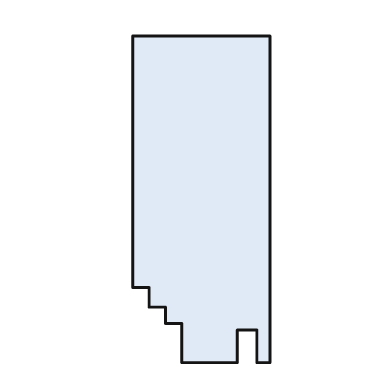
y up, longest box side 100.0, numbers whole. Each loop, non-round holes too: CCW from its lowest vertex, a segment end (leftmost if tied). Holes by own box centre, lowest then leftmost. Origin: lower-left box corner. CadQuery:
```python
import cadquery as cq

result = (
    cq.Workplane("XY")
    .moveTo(15.0, 0.0)
    .lineTo(32.0, 0.0)
    .lineTo(32.0, 10.0)
    .lineTo(38.0, 10.0)
    .lineTo(38.0, 0.0)
    .lineTo(42.0, 0.0)
    .lineTo(42.0, 100.0)
    .lineTo(0.0, 100.0)
    .lineTo(0.0, 23.0)
    .lineTo(5.0, 23.0)
    .lineTo(5.0, 17.0)
    .lineTo(10.0, 17.0)
    .lineTo(10.0, 12.0)
    .lineTo(15.0, 12.0)
    .close()
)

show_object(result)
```